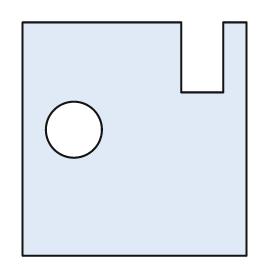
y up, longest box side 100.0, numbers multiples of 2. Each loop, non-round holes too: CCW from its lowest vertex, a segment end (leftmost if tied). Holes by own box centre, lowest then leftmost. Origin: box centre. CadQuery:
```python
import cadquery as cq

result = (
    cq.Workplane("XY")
    .moveTo(-48.0, -50.0)
    .lineTo(48.0, -50.0)
    .lineTo(48.0, 50.0)
    .lineTo(38.0, 50.0)
    .lineTo(38.0, 20.0)
    .lineTo(20.0, 20.0)
    .lineTo(20.0, 50.0)
    .lineTo(-48.0, 50.0)
    .close()
    .moveTo(-26.0, 4.0)
    .circle(12.0)
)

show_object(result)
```